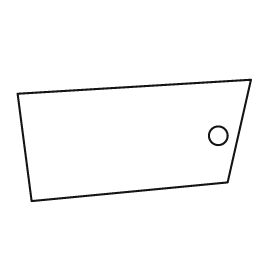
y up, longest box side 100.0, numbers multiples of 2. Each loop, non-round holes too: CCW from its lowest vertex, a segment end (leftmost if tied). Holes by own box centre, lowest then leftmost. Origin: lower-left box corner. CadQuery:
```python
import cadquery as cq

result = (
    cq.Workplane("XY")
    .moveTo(6.0, 0.0)
    .lineTo(90.0, 8.0)
    .lineTo(100.0, 52.0)
    .lineTo(0.0, 46.0)
    .close()
    .moveTo(86.0, 28.0)
    .circle(4.0)
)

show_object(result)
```